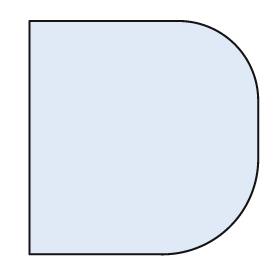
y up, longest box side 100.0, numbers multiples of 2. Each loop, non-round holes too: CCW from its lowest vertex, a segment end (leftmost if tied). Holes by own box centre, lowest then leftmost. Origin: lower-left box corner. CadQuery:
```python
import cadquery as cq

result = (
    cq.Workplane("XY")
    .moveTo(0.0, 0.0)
    .lineTo(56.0, 0.0)
    .threePointArc((86.0, 12.0), (98.0, 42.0))
    .lineTo(98.0, 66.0)
    .threePointArc((88.0, 90.0), (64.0, 100.0))
    .lineTo(0.0, 100.0)
    .close()
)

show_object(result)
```